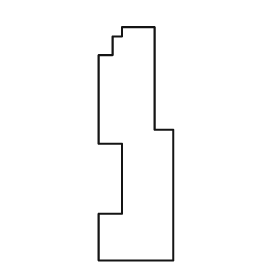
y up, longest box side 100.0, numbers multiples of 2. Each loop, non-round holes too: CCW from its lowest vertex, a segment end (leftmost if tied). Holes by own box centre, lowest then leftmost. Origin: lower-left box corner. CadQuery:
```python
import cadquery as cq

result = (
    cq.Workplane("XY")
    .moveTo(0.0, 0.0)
    .lineTo(32.0, 0.0)
    .lineTo(32.0, 56.0)
    .lineTo(24.0, 56.0)
    .lineTo(24.0, 100.0)
    .lineTo(10.0, 100.0)
    .lineTo(10.0, 96.0)
    .lineTo(6.0, 96.0)
    .lineTo(6.0, 88.0)
    .lineTo(0.0, 88.0)
    .lineTo(0.0, 50.0)
    .lineTo(10.0, 50.0)
    .lineTo(10.0, 20.0)
    .lineTo(0.0, 20.0)
    .close()
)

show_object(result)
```